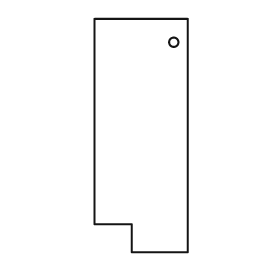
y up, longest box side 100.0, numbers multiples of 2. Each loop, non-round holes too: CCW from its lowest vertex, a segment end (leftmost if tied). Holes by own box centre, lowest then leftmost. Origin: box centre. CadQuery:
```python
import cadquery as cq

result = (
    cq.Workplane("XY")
    .moveTo(-4.0, -50.0)
    .lineTo(20.0, -50.0)
    .lineTo(20.0, 50.0)
    .lineTo(-20.0, 50.0)
    .lineTo(-20.0, -38.0)
    .lineTo(-4.0, -38.0)
    .close()
    .moveTo(14.0, 40.0)
    .circle(2.0)
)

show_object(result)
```